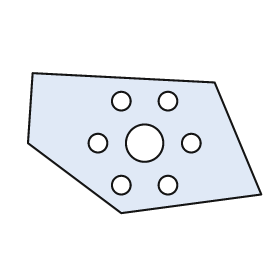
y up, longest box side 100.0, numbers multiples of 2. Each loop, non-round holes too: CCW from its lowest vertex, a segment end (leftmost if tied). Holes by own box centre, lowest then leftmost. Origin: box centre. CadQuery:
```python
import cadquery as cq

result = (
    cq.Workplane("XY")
    .moveTo(-10.0, -30.0)
    .lineTo(50.0, -22.0)
    .lineTo(30.0, 26.0)
    .lineTo(-48.0, 30.0)
    .lineTo(-50.0, 0.0)
    .close()
    .moveTo(-10.0, -18.0)
    .circle(4.0)
    .moveTo(10.0, -18.0)
    .circle(4.0)
    .moveTo(-20.0, 0.0)
    .circle(4.0)
    .moveTo(0.0, 0.0)
    .circle(8.0)
    .moveTo(20.0, 0.0)
    .circle(4.0)
    .moveTo(-10.0, 18.0)
    .circle(4.0)
    .moveTo(10.0, 18.0)
    .circle(4.0)
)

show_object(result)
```